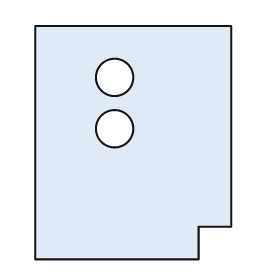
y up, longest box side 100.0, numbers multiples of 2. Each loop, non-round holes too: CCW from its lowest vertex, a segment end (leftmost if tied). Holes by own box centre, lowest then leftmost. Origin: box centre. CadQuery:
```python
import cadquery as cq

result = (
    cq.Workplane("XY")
    .moveTo(-42.0, -50.0)
    .lineTo(28.0, -50.0)
    .lineTo(28.0, -36.0)
    .lineTo(42.0, -36.0)
    .lineTo(42.0, 50.0)
    .lineTo(-42.0, 50.0)
    .close()
    .moveTo(-8.0, 6.0)
    .circle(8.0)
    .moveTo(-8.0, 28.0)
    .circle(8.0)
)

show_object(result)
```